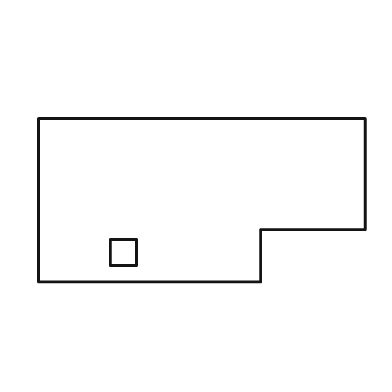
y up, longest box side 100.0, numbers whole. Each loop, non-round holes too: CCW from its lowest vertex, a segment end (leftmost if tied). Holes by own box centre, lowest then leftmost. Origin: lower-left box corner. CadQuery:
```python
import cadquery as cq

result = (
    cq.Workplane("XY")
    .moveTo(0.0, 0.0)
    .lineTo(68.0, 0.0)
    .lineTo(68.0, 16.0)
    .lineTo(100.0, 16.0)
    .lineTo(100.0, 50.0)
    .lineTo(0.0, 50.0)
    .close()
    .moveTo(22.0, 5.0)
    .lineTo(30.0, 5.0)
    .lineTo(30.0, 13.0)
    .lineTo(22.0, 13.0)
    .close()
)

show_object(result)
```